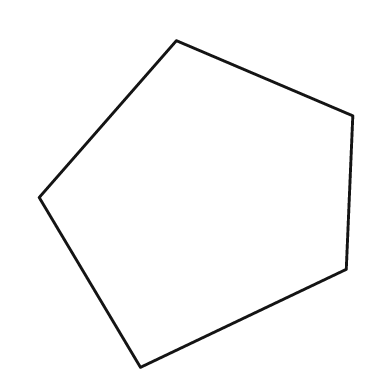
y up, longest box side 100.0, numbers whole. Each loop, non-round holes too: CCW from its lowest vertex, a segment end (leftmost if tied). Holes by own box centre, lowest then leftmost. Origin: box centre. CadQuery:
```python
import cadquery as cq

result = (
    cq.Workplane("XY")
    .moveTo(-17.0, -50.0)
    .lineTo(46.0, -20.0)
    .lineTo(48.0, 27.0)
    .lineTo(-6.0, 50.0)
    .lineTo(-48.0, 2.0)
    .close()
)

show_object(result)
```